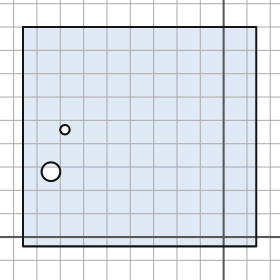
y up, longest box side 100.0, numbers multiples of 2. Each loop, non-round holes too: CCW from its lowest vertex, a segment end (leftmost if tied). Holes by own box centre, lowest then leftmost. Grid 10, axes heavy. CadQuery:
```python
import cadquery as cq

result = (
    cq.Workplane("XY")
    .moveTo(-86.0, -4.0)
    .lineTo(14.0, -4.0)
    .lineTo(14.0, 90.0)
    .lineTo(-86.0, 90.0)
    .close()
    .moveTo(-74.0, 28.0)
    .circle(4.0)
    .moveTo(-68.0, 46.0)
    .circle(2.0)
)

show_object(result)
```